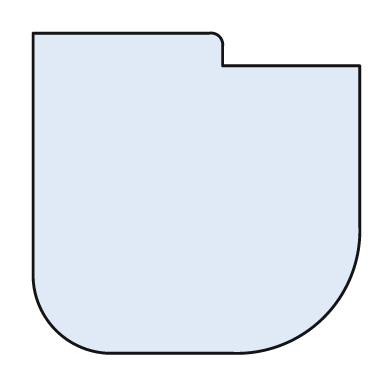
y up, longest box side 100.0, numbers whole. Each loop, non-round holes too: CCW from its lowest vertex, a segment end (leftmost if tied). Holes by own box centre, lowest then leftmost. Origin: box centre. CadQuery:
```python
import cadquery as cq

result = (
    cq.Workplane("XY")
    .moveTo(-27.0, -49.0)
    .lineTo(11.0, -49.0)
    .threePointArc((39.0, -38.0), (50.0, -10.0))
    .lineTo(50.0, 39.0)
    .lineTo(8.0, 39.0)
    .lineTo(8.0, 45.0)
    .threePointArc((7.0, 48.0), (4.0, 49.0))
    .lineTo(-50.0, 49.0)
    .lineTo(-50.0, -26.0)
    .threePointArc((-43.0, -42.0), (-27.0, -49.0))
    .close()
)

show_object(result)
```